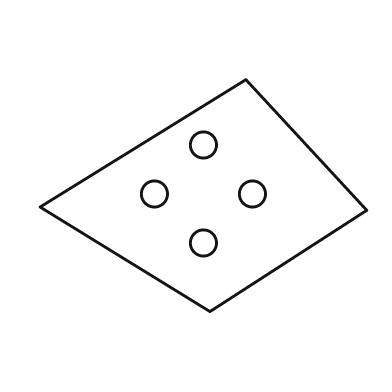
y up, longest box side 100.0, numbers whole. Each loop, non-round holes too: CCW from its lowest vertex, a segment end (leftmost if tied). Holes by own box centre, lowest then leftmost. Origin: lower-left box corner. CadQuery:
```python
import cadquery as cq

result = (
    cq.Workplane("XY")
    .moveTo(52.0, 0.0)
    .lineTo(100.0, 31.0)
    .lineTo(63.0, 71.0)
    .lineTo(0.0, 32.0)
    .close()
    .moveTo(50.0, 21.0)
    .circle(4.0)
    .moveTo(35.0, 36.0)
    .circle(4.0)
    .moveTo(65.0, 36.0)
    .circle(4.0)
    .moveTo(50.0, 51.0)
    .circle(4.0)
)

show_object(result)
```